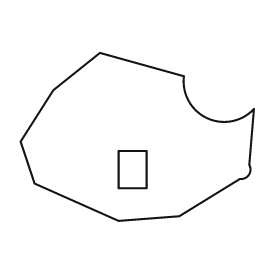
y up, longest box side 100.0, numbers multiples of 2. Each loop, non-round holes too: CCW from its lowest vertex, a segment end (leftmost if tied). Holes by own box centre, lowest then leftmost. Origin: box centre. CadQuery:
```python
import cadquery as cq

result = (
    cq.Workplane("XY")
    .moveTo(-8.0, -36.0)
    .lineTo(18.0, -34.0)
    .lineTo(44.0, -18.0)
    .threePointArc((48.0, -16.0), (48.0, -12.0))
    .lineTo(50.0, 12.0)
    .threePointArc((30.0, 8.0), (20.0, 26.0))
    .lineTo(-16.0, 36.0)
    .lineTo(-36.0, 20.0)
    .lineTo(-50.0, -2.0)
    .lineTo(-44.0, -20.0)
    .close()
    .moveTo(-8.0, -22.0)
    .lineTo(4.0, -22.0)
    .lineTo(4.0, -6.0)
    .lineTo(-8.0, -6.0)
    .close()
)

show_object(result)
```